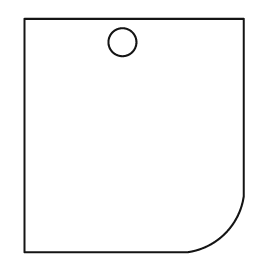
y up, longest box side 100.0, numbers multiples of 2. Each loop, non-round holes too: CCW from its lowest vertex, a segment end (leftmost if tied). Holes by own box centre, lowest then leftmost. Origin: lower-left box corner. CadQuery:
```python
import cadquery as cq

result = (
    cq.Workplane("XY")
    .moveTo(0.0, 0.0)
    .lineTo(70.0, 0.0)
    .threePointArc((86.0, 8.0), (94.0, 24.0))
    .lineTo(94.0, 100.0)
    .lineTo(0.0, 100.0)
    .close()
    .moveTo(42.0, 90.0)
    .circle(6.0)
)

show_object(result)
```